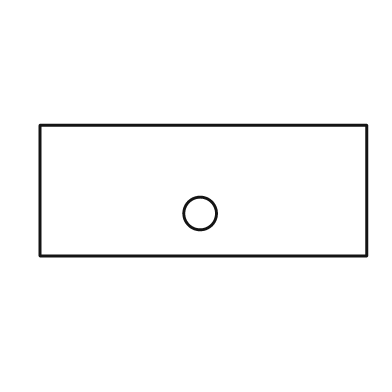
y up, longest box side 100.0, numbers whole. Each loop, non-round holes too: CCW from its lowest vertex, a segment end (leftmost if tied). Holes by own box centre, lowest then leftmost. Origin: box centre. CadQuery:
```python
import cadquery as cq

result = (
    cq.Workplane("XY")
    .moveTo(-50.0, -20.0)
    .lineTo(50.0, -20.0)
    .lineTo(50.0, 20.0)
    .lineTo(-50.0, 20.0)
    .close()
    .moveTo(-1.0, -7.0)
    .circle(5.0)
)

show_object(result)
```